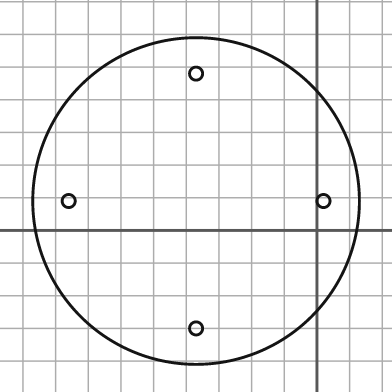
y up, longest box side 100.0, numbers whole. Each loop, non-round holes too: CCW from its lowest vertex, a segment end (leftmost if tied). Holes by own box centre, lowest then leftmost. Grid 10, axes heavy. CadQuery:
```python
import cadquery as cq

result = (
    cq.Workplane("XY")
    .moveTo(-37.0, 9.0)
    .circle(50.0)
    .moveTo(-37.0, -30.0)
    .circle(2.0)
    .moveTo(-76.0, 9.0)
    .circle(2.0)
    .moveTo(2.0, 9.0)
    .circle(2.0)
    .moveTo(-37.0, 48.0)
    .circle(2.0)
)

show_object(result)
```